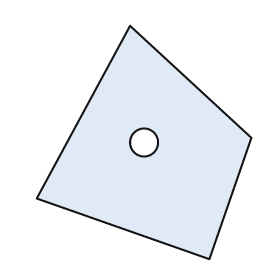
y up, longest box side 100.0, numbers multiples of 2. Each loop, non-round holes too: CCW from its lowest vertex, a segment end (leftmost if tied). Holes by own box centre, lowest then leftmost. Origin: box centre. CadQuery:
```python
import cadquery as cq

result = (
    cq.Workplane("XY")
    .moveTo(28.0, -50.0)
    .lineTo(46.0, 2.0)
    .lineTo(-6.0, 50.0)
    .lineTo(-46.0, -24.0)
    .close()
    .moveTo(0.0, 0.0)
    .circle(6.0)
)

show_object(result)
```